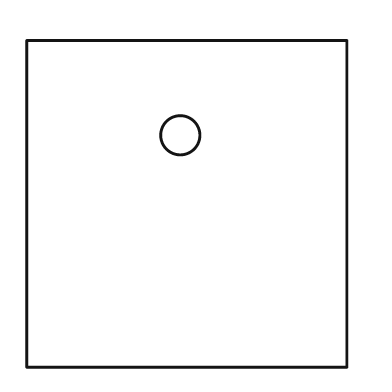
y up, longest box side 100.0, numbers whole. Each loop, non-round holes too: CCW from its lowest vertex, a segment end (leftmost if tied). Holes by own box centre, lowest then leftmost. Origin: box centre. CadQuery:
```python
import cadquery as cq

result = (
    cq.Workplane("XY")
    .moveTo(-49.0, -50.0)
    .lineTo(49.0, -50.0)
    .lineTo(49.0, 50.0)
    .lineTo(-49.0, 50.0)
    .close()
    .moveTo(-2.0, 21.0)
    .circle(6.0)
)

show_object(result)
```